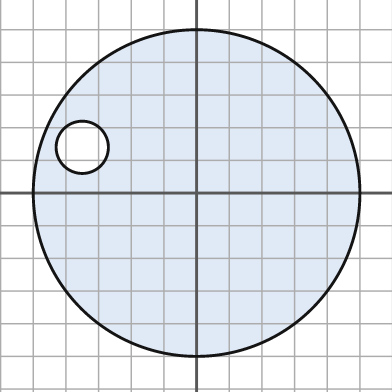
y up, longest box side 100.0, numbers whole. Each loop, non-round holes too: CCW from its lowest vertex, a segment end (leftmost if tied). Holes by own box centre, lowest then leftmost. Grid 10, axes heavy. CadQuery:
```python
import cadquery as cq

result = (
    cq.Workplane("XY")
    .moveTo(0.0, 0.0)
    .circle(50.0)
    .moveTo(-35.0, 14.0)
    .circle(8.0)
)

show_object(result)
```